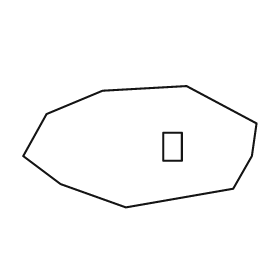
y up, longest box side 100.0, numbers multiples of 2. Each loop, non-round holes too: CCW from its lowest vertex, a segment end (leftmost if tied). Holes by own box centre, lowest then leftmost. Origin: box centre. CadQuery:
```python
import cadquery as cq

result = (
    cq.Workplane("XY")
    .moveTo(-6.0, -26.0)
    .lineTo(40.0, -18.0)
    .lineTo(48.0, -4.0)
    .lineTo(50.0, 10.0)
    .lineTo(20.0, 26.0)
    .lineTo(-16.0, 24.0)
    .lineTo(-40.0, 14.0)
    .lineTo(-50.0, -4.0)
    .lineTo(-34.0, -16.0)
    .close()
    .moveTo(10.0, -6.0)
    .lineTo(18.0, -6.0)
    .lineTo(18.0, 6.0)
    .lineTo(10.0, 6.0)
    .close()
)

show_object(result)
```